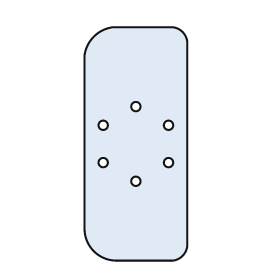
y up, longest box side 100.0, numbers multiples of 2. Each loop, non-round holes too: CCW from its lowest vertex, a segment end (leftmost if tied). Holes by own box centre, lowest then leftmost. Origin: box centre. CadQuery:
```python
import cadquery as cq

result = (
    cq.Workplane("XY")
    .moveTo(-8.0, -50.0)
    .lineTo(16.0, -50.0)
    .threePointArc((20.0, -48.0), (22.0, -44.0))
    .lineTo(22.0, 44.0)
    .threePointArc((20.0, 48.0), (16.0, 50.0))
    .lineTo(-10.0, 50.0)
    .threePointArc((-18.0, 46.0), (-22.0, 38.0))
    .lineTo(-22.0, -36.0)
    .threePointArc((-18.0, -46.0), (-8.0, -50.0))
    .close()
    .moveTo(0.0, -16.0)
    .circle(2.0)
    .moveTo(-14.0, -8.0)
    .circle(2.0)
    .moveTo(14.0, -8.0)
    .circle(2.0)
    .moveTo(-14.0, 8.0)
    .circle(2.0)
    .moveTo(14.0, 8.0)
    .circle(2.0)
    .moveTo(0.0, 16.0)
    .circle(2.0)
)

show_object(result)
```